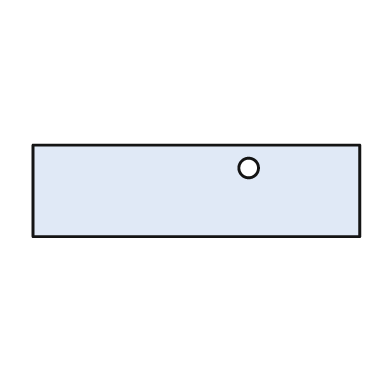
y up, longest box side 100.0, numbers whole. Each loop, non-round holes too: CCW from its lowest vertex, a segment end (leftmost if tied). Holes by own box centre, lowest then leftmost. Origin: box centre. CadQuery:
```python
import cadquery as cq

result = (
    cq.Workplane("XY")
    .moveTo(-50.0, -14.0)
    .lineTo(50.0, -14.0)
    .lineTo(50.0, 14.0)
    .lineTo(-50.0, 14.0)
    .close()
    .moveTo(16.0, 7.0)
    .circle(3.0)
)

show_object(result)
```